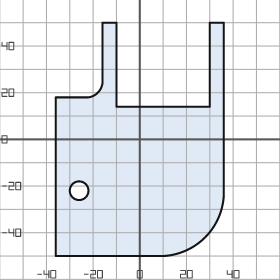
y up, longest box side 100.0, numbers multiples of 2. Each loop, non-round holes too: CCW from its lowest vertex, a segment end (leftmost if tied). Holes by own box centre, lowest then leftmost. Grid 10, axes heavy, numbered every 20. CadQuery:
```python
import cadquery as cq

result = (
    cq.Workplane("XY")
    .moveTo(-36.0, -50.0)
    .lineTo(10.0, -50.0)
    .threePointArc((28.0, -42.0), (36.0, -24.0))
    .lineTo(36.0, 50.0)
    .lineTo(30.0, 50.0)
    .lineTo(30.0, 14.0)
    .lineTo(-10.0, 14.0)
    .lineTo(-10.0, 50.0)
    .lineTo(-16.0, 50.0)
    .lineTo(-16.0, 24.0)
    .threePointArc((-18.0, 20.0), (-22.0, 18.0))
    .lineTo(-36.0, 18.0)
    .close()
    .moveTo(-26.0, -22.0)
    .circle(4.0)
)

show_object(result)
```